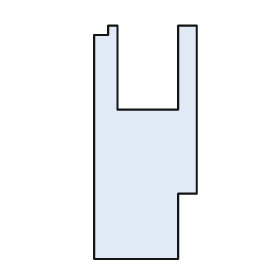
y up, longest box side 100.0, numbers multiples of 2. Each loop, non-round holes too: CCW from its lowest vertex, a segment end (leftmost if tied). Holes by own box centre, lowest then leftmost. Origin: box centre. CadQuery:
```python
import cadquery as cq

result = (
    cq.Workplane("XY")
    .moveTo(-22.0, -50.0)
    .lineTo(14.0, -50.0)
    .lineTo(14.0, -22.0)
    .lineTo(22.0, -22.0)
    .lineTo(22.0, 50.0)
    .lineTo(14.0, 50.0)
    .lineTo(14.0, 14.0)
    .lineTo(-12.0, 14.0)
    .lineTo(-12.0, 50.0)
    .lineTo(-16.0, 50.0)
    .lineTo(-16.0, 46.0)
    .lineTo(-22.0, 46.0)
    .close()
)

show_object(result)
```